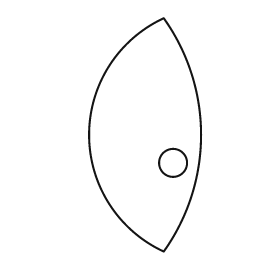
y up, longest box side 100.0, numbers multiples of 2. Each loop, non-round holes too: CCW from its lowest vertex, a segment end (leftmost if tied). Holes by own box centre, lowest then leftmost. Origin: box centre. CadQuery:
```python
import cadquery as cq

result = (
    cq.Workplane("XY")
    .moveTo(8.0, -50.0)
    .threePointArc((24.0, 0.0), (8.0, 50.0))
    .threePointArc((-24.0, 0.0), (8.0, -50.0))
    .close()
    .moveTo(12.0, -12.0)
    .circle(6.0)
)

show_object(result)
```